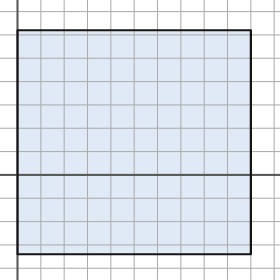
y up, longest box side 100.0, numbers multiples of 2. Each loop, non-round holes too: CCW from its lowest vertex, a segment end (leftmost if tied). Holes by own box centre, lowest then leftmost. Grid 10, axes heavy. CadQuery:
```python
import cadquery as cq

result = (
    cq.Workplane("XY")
    .moveTo(0.0, -34.0)
    .lineTo(100.0, -34.0)
    .lineTo(100.0, 62.0)
    .lineTo(0.0, 62.0)
    .close()
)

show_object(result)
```